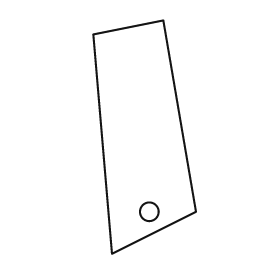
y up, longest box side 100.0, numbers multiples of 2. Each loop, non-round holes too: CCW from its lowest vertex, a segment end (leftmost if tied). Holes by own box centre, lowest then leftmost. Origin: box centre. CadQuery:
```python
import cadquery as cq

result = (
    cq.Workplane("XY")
    .moveTo(-14.0, -50.0)
    .lineTo(22.0, -32.0)
    .lineTo(8.0, 50.0)
    .lineTo(-22.0, 44.0)
    .close()
    .moveTo(2.0, -32.0)
    .circle(4.0)
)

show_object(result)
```